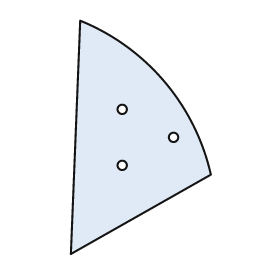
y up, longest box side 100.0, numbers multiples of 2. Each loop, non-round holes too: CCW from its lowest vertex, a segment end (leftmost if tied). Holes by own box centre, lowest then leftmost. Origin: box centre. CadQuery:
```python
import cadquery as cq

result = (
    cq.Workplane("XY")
    .moveTo(-30.0, -50.0)
    .lineTo(30.0, -16.0)
    .threePointArc((10.0, 24.0), (-26.0, 50.0))
    .close()
    .moveTo(-8.0, -12.0)
    .circle(2.0)
    .moveTo(14.0, 0.0)
    .circle(2.0)
    .moveTo(-8.0, 12.0)
    .circle(2.0)
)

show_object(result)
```